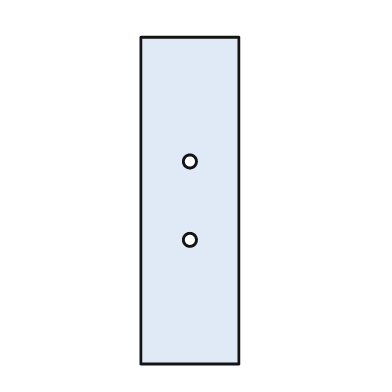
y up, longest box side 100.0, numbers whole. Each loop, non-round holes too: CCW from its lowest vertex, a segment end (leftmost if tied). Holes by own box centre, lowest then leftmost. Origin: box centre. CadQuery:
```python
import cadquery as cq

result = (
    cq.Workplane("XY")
    .moveTo(-15.0, -50.0)
    .lineTo(15.0, -50.0)
    .lineTo(15.0, 50.0)
    .lineTo(-15.0, 50.0)
    .close()
    .moveTo(0.0, -12.0)
    .circle(2.0)
    .moveTo(0.0, 12.0)
    .circle(2.0)
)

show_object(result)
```